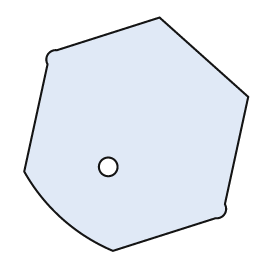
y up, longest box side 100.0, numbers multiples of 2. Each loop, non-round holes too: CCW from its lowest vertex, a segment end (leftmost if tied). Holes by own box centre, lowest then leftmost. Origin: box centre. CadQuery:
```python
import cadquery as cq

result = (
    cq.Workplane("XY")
    .moveTo(-10.0, -50.0)
    .lineTo(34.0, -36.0)
    .threePointArc((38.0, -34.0), (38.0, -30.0))
    .lineTo(48.0, 16.0)
    .lineTo(10.0, 50.0)
    .lineTo(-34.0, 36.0)
    .threePointArc((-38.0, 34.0), (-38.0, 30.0))
    .lineTo(-48.0, -16.0)
    .threePointArc((-32.0, -36.0), (-10.0, -50.0))
    .close()
    .moveTo(-12.0, -14.0)
    .circle(4.0)
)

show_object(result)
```